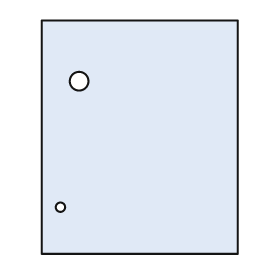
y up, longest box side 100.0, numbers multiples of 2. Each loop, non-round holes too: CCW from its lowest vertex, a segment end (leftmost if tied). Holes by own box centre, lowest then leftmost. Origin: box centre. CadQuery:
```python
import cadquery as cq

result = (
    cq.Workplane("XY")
    .moveTo(-42.0, -50.0)
    .lineTo(42.0, -50.0)
    .lineTo(42.0, 50.0)
    .lineTo(-42.0, 50.0)
    .close()
    .moveTo(-34.0, -30.0)
    .circle(2.0)
    .moveTo(-26.0, 24.0)
    .circle(4.0)
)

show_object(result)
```